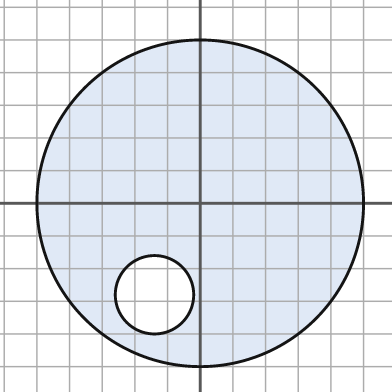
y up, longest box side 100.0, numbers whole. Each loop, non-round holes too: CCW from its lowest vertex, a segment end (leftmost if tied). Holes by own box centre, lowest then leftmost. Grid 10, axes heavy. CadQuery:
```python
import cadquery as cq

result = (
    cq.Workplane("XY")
    .moveTo(0.0, 0.0)
    .circle(50.0)
    .moveTo(-14.0, -28.0)
    .circle(12.0)
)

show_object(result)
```